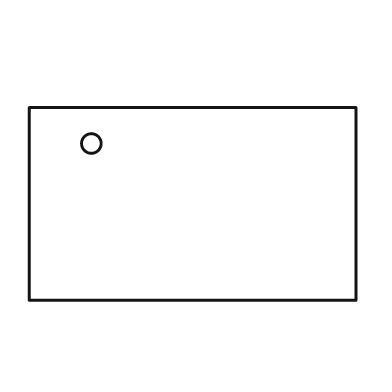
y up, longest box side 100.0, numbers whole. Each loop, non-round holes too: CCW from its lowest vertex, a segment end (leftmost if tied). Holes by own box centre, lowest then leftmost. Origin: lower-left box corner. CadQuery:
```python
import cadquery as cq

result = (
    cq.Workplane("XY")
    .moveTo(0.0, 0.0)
    .lineTo(100.0, 0.0)
    .lineTo(100.0, 59.0)
    .lineTo(0.0, 59.0)
    .close()
    .moveTo(19.0, 48.0)
    .circle(3.0)
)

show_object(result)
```